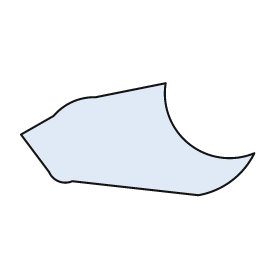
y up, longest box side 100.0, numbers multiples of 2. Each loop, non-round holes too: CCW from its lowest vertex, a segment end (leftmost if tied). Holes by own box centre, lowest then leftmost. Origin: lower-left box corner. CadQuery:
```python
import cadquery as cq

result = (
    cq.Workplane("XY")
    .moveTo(76.0, 0.0)
    .threePointArc((90.0, 6.0), (100.0, 18.0))
    .threePointArc((72.0, 22.0), (62.0, 48.0))
    .lineTo(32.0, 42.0)
    .threePointArc((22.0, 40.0), (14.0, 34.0))
    .lineTo(0.0, 26.0)
    .lineTo(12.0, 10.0)
    .threePointArc((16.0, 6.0), (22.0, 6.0))
    .close()
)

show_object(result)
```